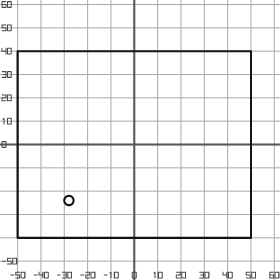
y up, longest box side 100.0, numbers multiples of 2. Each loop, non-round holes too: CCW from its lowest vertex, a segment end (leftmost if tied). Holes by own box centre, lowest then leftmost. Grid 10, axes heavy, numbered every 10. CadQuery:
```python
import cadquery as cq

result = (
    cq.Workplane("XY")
    .moveTo(-50.0, -40.0)
    .lineTo(50.0, -40.0)
    .lineTo(50.0, 40.0)
    .lineTo(-50.0, 40.0)
    .close()
    .moveTo(-28.0, -24.0)
    .circle(2.0)
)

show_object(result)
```